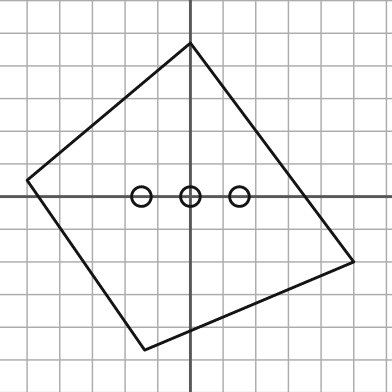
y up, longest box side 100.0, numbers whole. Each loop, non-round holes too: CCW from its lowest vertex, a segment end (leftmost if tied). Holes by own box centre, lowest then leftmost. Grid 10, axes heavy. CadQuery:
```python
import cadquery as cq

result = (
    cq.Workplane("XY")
    .moveTo(-14.0, -47.0)
    .lineTo(50.0, -20.0)
    .lineTo(0.0, 47.0)
    .lineTo(-50.0, 5.0)
    .close()
    .moveTo(-15.0, 0.0)
    .circle(3.0)
    .moveTo(0.0, 0.0)
    .circle(3.0)
    .moveTo(15.0, 0.0)
    .circle(3.0)
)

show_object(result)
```